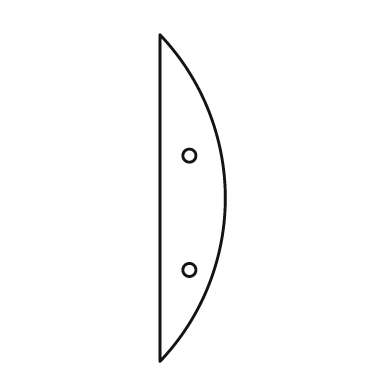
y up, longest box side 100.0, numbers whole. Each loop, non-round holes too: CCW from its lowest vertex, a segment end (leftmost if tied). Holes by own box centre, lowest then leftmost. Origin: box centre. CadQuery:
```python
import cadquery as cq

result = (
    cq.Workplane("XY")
    .moveTo(-10.0, -50.0)
    .threePointArc((10.0, 0.0), (-10.0, 50.0))
    .close()
    .moveTo(-1.0, -22.0)
    .circle(2.0)
    .moveTo(-1.0, 13.0)
    .circle(2.0)
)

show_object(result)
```